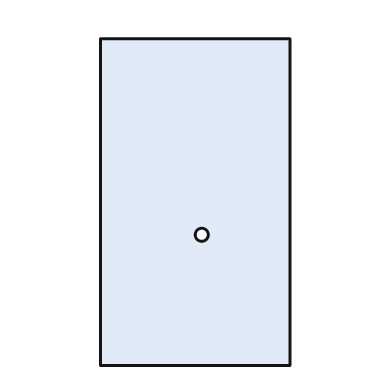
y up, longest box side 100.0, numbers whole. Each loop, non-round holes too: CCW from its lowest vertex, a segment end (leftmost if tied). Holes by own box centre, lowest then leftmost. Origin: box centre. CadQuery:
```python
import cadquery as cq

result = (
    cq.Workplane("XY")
    .moveTo(-29.0, -50.0)
    .lineTo(29.0, -50.0)
    .lineTo(29.0, 50.0)
    .lineTo(-29.0, 50.0)
    .close()
    .moveTo(2.0, -10.0)
    .circle(2.0)
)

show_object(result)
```